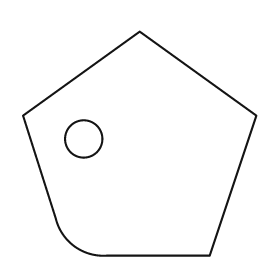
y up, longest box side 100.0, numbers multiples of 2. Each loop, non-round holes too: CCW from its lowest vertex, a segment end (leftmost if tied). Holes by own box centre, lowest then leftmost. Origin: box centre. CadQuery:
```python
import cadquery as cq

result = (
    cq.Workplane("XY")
    .moveTo(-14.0, -48.0)
    .lineTo(30.0, -48.0)
    .lineTo(50.0, 12.0)
    .lineTo(0.0, 48.0)
    .lineTo(-50.0, 12.0)
    .lineTo(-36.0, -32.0)
    .threePointArc((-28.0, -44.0), (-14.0, -48.0))
    .close()
    .moveTo(-24.0, 2.0)
    .circle(8.0)
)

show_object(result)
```